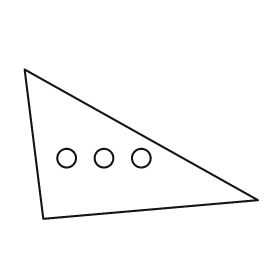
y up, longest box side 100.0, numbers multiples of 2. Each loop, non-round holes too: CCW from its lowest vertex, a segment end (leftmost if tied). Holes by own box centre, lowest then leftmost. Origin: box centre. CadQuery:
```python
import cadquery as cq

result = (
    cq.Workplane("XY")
    .moveTo(-42.0, -32.0)
    .lineTo(50.0, -24.0)
    .lineTo(-50.0, 32.0)
    .close()
    .moveTo(-32.0, -6.0)
    .circle(4.0)
    .moveTo(-16.0, -6.0)
    .circle(4.0)
    .moveTo(0.0, -6.0)
    .circle(4.0)
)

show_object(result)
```